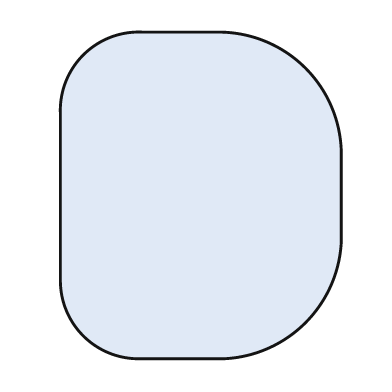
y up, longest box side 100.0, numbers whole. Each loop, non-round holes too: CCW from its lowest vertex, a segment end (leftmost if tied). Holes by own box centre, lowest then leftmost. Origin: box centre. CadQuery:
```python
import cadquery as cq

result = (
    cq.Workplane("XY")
    .moveTo(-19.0, -50.0)
    .lineTo(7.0, -50.0)
    .threePointArc((32.0, -39.0), (43.0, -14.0))
    .lineTo(43.0, 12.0)
    .threePointArc((32.0, 39.0), (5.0, 50.0))
    .lineTo(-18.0, 50.0)
    .threePointArc((-36.0, 43.0), (-43.0, 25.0))
    .lineTo(-43.0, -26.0)
    .threePointArc((-36.0, -43.0), (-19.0, -50.0))
    .close()
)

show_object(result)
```